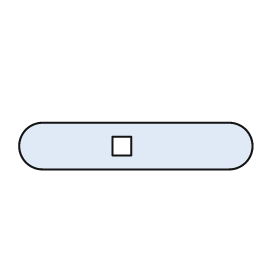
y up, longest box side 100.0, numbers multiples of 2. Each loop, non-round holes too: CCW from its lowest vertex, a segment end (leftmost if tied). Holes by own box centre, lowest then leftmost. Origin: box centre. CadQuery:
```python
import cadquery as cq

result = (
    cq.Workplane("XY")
    .moveTo(-40.0, -10.0)
    .lineTo(40.0, -10.0)
    .threePointArc((50.0, 0.0), (40.0, 10.0))
    .lineTo(-40.0, 10.0)
    .threePointArc((-50.0, 0.0), (-40.0, -10.0))
    .close()
    .moveTo(-10.0, -4.0)
    .lineTo(-2.0, -4.0)
    .lineTo(-2.0, 4.0)
    .lineTo(-10.0, 4.0)
    .close()
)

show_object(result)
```